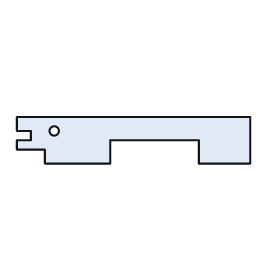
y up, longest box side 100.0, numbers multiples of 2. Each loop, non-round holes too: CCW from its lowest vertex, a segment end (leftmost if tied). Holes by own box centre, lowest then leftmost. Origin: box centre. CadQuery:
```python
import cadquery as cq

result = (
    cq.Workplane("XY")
    .moveTo(-38.0, -10.0)
    .lineTo(-10.0, -10.0)
    .lineTo(-10.0, 0.0)
    .lineTo(28.0, 0.0)
    .lineTo(28.0, -10.0)
    .lineTo(50.0, -10.0)
    .lineTo(50.0, 10.0)
    .lineTo(-50.0, 10.0)
    .lineTo(-50.0, 4.0)
    .lineTo(-44.0, 4.0)
    .lineTo(-44.0, 0.0)
    .lineTo(-50.0, 0.0)
    .lineTo(-50.0, -4.0)
    .lineTo(-38.0, -4.0)
    .close()
    .moveTo(-34.0, 4.0)
    .circle(2.0)
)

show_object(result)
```